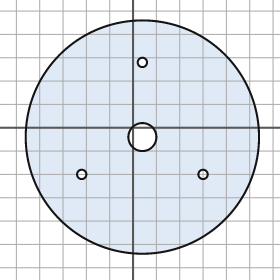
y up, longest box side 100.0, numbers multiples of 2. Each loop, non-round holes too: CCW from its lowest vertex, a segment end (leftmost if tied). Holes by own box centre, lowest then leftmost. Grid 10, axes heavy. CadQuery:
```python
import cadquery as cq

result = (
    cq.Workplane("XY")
    .moveTo(4.0, -4.0)
    .circle(50.0)
    .moveTo(-22.0, -20.0)
    .circle(2.0)
    .moveTo(30.0, -20.0)
    .circle(2.0)
    .moveTo(4.0, -4.0)
    .circle(6.0)
    .moveTo(4.0, 28.0)
    .circle(2.0)
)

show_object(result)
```